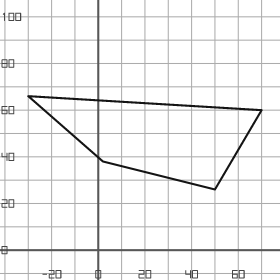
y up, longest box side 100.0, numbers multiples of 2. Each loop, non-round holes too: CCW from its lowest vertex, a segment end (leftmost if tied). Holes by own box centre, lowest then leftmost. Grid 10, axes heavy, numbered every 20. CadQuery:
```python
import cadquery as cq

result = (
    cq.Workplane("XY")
    .moveTo(50.0, 26.0)
    .lineTo(70.0, 60.0)
    .lineTo(-30.0, 66.0)
    .lineTo(2.0, 38.0)
    .close()
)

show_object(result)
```